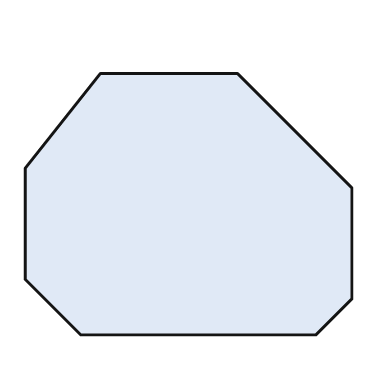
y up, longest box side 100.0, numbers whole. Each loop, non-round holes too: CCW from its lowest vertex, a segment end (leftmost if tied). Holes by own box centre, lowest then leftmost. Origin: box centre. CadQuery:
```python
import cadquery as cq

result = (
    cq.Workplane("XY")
    .moveTo(-33.0, -40.0)
    .lineTo(39.0, -40.0)
    .lineTo(50.0, -29.0)
    .lineTo(50.0, 5.0)
    .lineTo(15.0, 40.0)
    .lineTo(-27.0, 40.0)
    .lineTo(-50.0, 11.0)
    .lineTo(-50.0, -23.0)
    .close()
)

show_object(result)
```